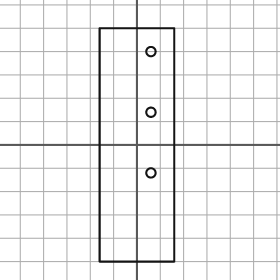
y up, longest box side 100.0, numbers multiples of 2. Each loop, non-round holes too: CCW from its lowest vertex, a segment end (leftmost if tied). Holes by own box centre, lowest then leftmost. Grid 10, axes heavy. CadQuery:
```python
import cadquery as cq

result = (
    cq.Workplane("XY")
    .moveTo(-16.0, -50.0)
    .lineTo(16.0, -50.0)
    .lineTo(16.0, 50.0)
    .lineTo(-16.0, 50.0)
    .close()
    .moveTo(6.0, -12.0)
    .circle(2.0)
    .moveTo(6.0, 14.0)
    .circle(2.0)
    .moveTo(6.0, 40.0)
    .circle(2.0)
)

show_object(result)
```